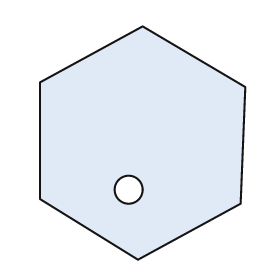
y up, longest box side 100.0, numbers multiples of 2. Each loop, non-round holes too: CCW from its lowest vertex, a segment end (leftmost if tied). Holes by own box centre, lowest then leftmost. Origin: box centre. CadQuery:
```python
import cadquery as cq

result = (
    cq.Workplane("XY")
    .moveTo(-2.0, -50.0)
    .lineTo(42.0, -26.0)
    .lineTo(44.0, 24.0)
    .lineTo(0.0, 50.0)
    .lineTo(-44.0, 26.0)
    .lineTo(-44.0, -24.0)
    .close()
    .moveTo(-6.0, -20.0)
    .circle(6.0)
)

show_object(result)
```